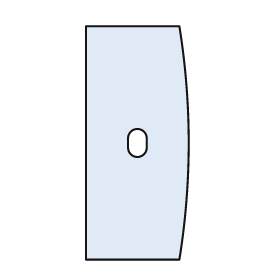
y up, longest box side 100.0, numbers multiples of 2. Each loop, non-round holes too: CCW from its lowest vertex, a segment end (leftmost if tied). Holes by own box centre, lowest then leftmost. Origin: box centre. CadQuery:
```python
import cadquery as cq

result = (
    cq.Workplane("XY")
    .moveTo(-22.0, -50.0)
    .lineTo(18.0, -50.0)
    .threePointArc((22.0, 0.0), (18.0, 50.0))
    .lineTo(-22.0, 50.0)
    .close()
    .moveTo(-4.0, -2.0)
    .threePointArc((0.0, -6.0), (4.0, -2.0))
    .lineTo(4.0, 2.0)
    .threePointArc((0.0, 6.0), (-4.0, 2.0))
    .close()
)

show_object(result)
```